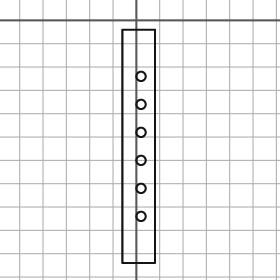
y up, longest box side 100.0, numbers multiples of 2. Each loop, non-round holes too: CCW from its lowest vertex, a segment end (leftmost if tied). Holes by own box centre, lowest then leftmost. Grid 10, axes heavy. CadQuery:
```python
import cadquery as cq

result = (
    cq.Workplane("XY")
    .moveTo(-6.0, -104.0)
    .lineTo(8.0, -104.0)
    .lineTo(8.0, -4.0)
    .lineTo(-6.0, -4.0)
    .close()
    .moveTo(2.0, -84.0)
    .circle(2.0)
    .moveTo(2.0, -72.0)
    .circle(2.0)
    .moveTo(2.0, -60.0)
    .circle(2.0)
    .moveTo(2.0, -48.0)
    .circle(2.0)
    .moveTo(2.0, -36.0)
    .circle(2.0)
    .moveTo(2.0, -24.0)
    .circle(2.0)
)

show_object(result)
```